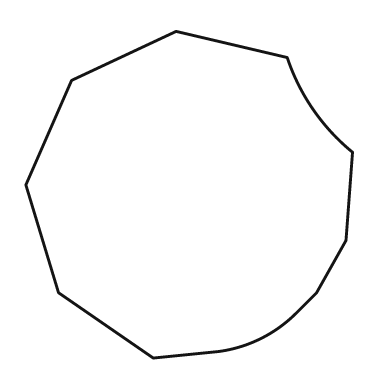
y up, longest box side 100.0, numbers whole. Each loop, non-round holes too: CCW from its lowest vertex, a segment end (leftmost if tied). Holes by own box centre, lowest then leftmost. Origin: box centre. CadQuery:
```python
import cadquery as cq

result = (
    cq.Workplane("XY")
    .moveTo(-11.0, -50.0)
    .lineTo(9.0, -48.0)
    .threePointArc((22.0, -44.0), (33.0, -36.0))
    .lineTo(39.0, -30.0)
    .lineTo(48.0, -14.0)
    .lineTo(50.0, 13.0)
    .threePointArc((38.0, 26.0), (30.0, 42.0))
    .lineTo(-4.0, 50.0)
    .lineTo(-36.0, 35.0)
    .lineTo(-50.0, 3.0)
    .lineTo(-40.0, -30.0)
    .close()
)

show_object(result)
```